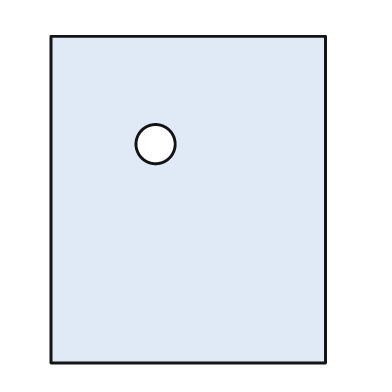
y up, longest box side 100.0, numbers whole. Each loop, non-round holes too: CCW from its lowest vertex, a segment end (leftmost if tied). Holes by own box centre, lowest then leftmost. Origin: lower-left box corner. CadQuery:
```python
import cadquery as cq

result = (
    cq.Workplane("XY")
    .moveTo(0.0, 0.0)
    .lineTo(84.0, 0.0)
    .lineTo(84.0, 100.0)
    .lineTo(0.0, 100.0)
    .close()
    .moveTo(32.0, 67.0)
    .circle(6.0)
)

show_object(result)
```